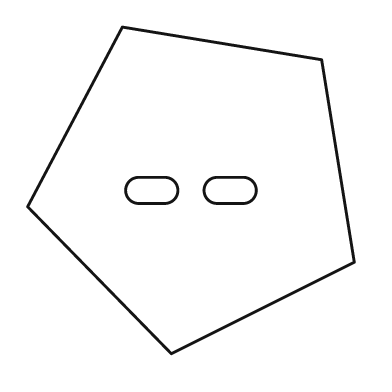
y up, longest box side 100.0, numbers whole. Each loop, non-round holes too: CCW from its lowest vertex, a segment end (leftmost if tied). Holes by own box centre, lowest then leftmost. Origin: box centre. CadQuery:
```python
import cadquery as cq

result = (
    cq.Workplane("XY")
    .moveTo(-6.0, -50.0)
    .lineTo(50.0, -22.0)
    .lineTo(40.0, 40.0)
    .lineTo(-21.0, 50.0)
    .lineTo(-50.0, -5.0)
    .close()
    .moveTo(-16.0, -4.0)
    .lineTo(-8.0, -4.0)
    .threePointArc((-4.0, 0.0), (-8.0, 4.0))
    .lineTo(-16.0, 4.0)
    .threePointArc((-20.0, 0.0), (-16.0, -4.0))
    .close()
    .moveTo(8.0, -4.0)
    .lineTo(16.0, -4.0)
    .threePointArc((20.0, 0.0), (16.0, 4.0))
    .lineTo(8.0, 4.0)
    .threePointArc((4.0, 0.0), (8.0, -4.0))
    .close()
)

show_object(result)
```